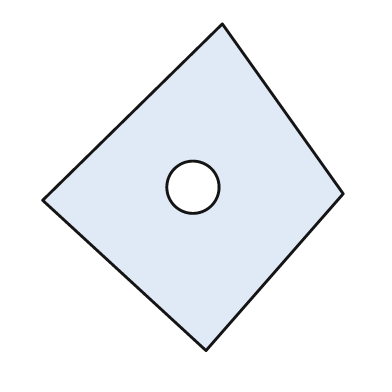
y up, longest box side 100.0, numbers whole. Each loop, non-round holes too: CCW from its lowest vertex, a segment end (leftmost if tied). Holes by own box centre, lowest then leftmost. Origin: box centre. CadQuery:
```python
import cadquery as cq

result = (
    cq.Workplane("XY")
    .moveTo(4.0, -50.0)
    .lineTo(46.0, -2.0)
    .lineTo(9.0, 50.0)
    .lineTo(-46.0, -4.0)
    .close()
    .moveTo(0.0, 0.0)
    .circle(8.0)
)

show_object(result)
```